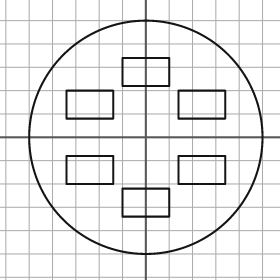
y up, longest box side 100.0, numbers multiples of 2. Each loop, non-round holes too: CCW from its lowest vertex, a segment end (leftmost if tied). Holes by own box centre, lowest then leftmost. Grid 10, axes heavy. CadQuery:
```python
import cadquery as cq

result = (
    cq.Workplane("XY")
    .moveTo(0.0, 0.0)
    .circle(50.0)
    .moveTo(-10.0, -34.0)
    .lineTo(10.0, -34.0)
    .lineTo(10.0, -22.0)
    .lineTo(-10.0, -22.0)
    .close()
    .moveTo(-34.0, -20.0)
    .lineTo(-14.0, -20.0)
    .lineTo(-14.0, -8.0)
    .lineTo(-34.0, -8.0)
    .close()
    .moveTo(14.0, -20.0)
    .lineTo(34.0, -20.0)
    .lineTo(34.0, -8.0)
    .lineTo(14.0, -8.0)
    .close()
    .moveTo(-34.0, 8.0)
    .lineTo(-14.0, 8.0)
    .lineTo(-14.0, 20.0)
    .lineTo(-34.0, 20.0)
    .close()
    .moveTo(14.0, 8.0)
    .lineTo(34.0, 8.0)
    .lineTo(34.0, 20.0)
    .lineTo(14.0, 20.0)
    .close()
    .moveTo(-10.0, 22.0)
    .lineTo(10.0, 22.0)
    .lineTo(10.0, 34.0)
    .lineTo(-10.0, 34.0)
    .close()
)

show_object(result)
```